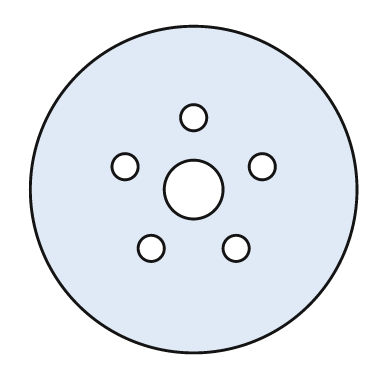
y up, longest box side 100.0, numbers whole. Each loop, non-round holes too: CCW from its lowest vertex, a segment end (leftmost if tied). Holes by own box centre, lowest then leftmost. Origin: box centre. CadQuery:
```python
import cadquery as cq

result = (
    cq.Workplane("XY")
    .moveTo(0.0, 0.0)
    .circle(50.0)
    .moveTo(-13.0, -18.0)
    .circle(4.0)
    .moveTo(13.0, -18.0)
    .circle(4.0)
    .moveTo(0.0, 0.0)
    .circle(9.0)
    .moveTo(-21.0, 7.0)
    .circle(4.0)
    .moveTo(21.0, 7.0)
    .circle(4.0)
    .moveTo(0.0, 22.0)
    .circle(4.0)
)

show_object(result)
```